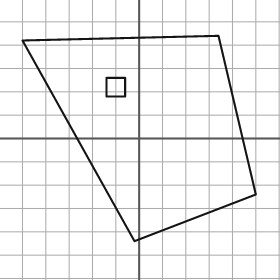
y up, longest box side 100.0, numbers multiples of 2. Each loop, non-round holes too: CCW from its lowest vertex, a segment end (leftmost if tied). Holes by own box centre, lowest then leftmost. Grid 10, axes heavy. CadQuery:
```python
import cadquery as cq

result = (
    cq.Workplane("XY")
    .moveTo(-2.0, -44.0)
    .lineTo(50.0, -24.0)
    .lineTo(34.0, 44.0)
    .lineTo(-50.0, 42.0)
    .close()
    .moveTo(-14.0, 18.0)
    .lineTo(-6.0, 18.0)
    .lineTo(-6.0, 26.0)
    .lineTo(-14.0, 26.0)
    .close()
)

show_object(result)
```